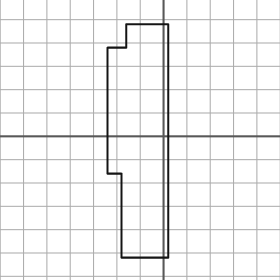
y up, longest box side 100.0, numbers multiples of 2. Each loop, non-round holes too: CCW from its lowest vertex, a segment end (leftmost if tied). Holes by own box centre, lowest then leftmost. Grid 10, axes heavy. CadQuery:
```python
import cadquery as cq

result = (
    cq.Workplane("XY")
    .moveTo(-18.0, -52.0)
    .lineTo(2.0, -52.0)
    .lineTo(2.0, 48.0)
    .lineTo(-16.0, 48.0)
    .lineTo(-16.0, 38.0)
    .lineTo(-24.0, 38.0)
    .lineTo(-24.0, -16.0)
    .lineTo(-18.0, -16.0)
    .close()
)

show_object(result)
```